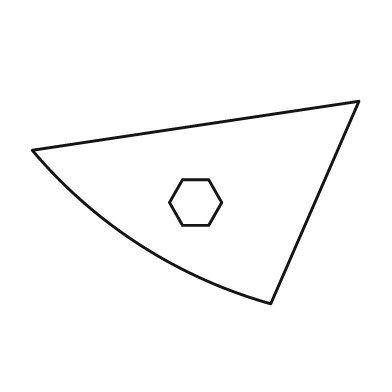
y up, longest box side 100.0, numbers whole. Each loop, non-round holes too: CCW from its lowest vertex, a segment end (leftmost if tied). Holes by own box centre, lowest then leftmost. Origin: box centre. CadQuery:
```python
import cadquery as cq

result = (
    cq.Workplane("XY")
    .moveTo(23.0, -31.0)
    .lineTo(50.0, 31.0)
    .lineTo(-50.0, 16.0)
    .threePointArc((-17.0, -13.0), (23.0, -31.0))
    .close()
    .moveTo(-4.0, -7.0)
    .lineTo(4.0, -7.0)
    .lineTo(8.0, 0.0)
    .lineTo(4.0, 7.0)
    .lineTo(-4.0, 7.0)
    .lineTo(-8.0, 0.0)
    .close()
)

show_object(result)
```